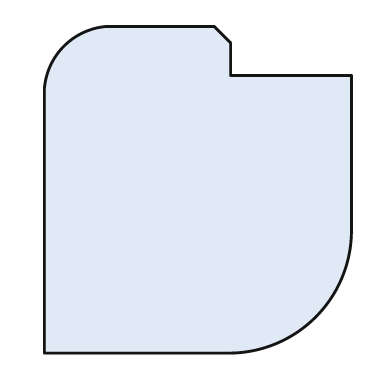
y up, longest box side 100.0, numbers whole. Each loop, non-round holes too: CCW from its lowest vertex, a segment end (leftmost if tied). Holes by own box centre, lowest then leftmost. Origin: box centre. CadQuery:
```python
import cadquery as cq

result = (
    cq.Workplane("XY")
    .moveTo(-47.0, -50.0)
    .lineTo(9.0, -50.0)
    .threePointArc((36.0, -39.0), (47.0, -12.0))
    .lineTo(47.0, 35.0)
    .lineTo(10.0, 35.0)
    .lineTo(10.0, 45.0)
    .lineTo(5.0, 50.0)
    .lineTo(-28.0, 50.0)
    .threePointArc((-41.0, 44.0), (-47.0, 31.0))
    .close()
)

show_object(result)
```